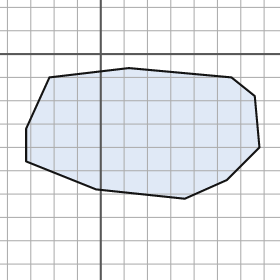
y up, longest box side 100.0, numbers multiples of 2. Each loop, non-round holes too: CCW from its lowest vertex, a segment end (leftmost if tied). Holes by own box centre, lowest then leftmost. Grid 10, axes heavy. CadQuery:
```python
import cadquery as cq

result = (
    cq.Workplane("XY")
    .moveTo(36.0, -62.0)
    .lineTo(54.0, -54.0)
    .lineTo(68.0, -40.0)
    .lineTo(66.0, -18.0)
    .lineTo(56.0, -10.0)
    .lineTo(12.0, -6.0)
    .lineTo(-22.0, -10.0)
    .lineTo(-32.0, -32.0)
    .lineTo(-32.0, -46.0)
    .lineTo(-2.0, -58.0)
    .close()
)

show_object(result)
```